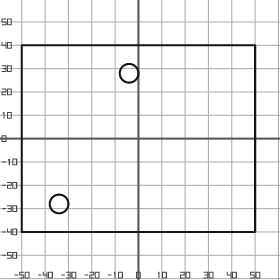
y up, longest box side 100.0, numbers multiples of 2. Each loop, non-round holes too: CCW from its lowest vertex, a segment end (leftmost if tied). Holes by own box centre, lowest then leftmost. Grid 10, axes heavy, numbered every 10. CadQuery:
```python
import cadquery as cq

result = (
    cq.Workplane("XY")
    .moveTo(-50.0, -40.0)
    .lineTo(50.0, -40.0)
    .lineTo(50.0, 40.0)
    .lineTo(-50.0, 40.0)
    .close()
    .moveTo(-34.0, -28.0)
    .circle(4.0)
    .moveTo(-4.0, 28.0)
    .circle(4.0)
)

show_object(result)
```